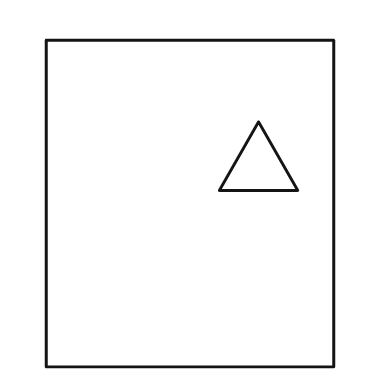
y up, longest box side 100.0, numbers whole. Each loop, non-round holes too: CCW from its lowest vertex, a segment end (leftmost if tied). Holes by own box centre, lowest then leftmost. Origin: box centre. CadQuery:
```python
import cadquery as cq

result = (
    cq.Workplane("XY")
    .moveTo(-44.0, -50.0)
    .lineTo(44.0, -50.0)
    .lineTo(44.0, 50.0)
    .lineTo(-44.0, 50.0)
    .close()
    .moveTo(9.0, 4.0)
    .lineTo(33.0, 4.0)
    .lineTo(21.0, 25.0)
    .close()
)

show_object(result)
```